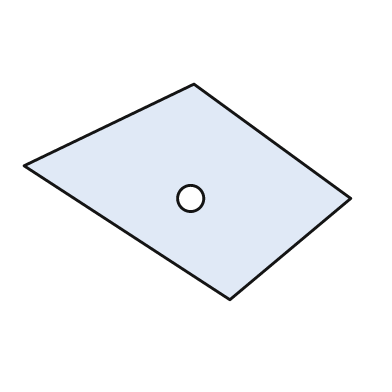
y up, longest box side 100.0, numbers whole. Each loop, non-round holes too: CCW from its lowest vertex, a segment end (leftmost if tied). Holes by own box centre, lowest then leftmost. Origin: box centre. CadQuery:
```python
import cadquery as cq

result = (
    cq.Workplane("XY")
    .moveTo(13.0, -33.0)
    .lineTo(50.0, -2.0)
    .lineTo(2.0, 33.0)
    .lineTo(-50.0, 8.0)
    .close()
    .moveTo(1.0, -2.0)
    .circle(4.0)
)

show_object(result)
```